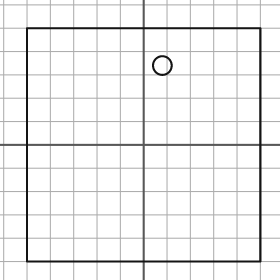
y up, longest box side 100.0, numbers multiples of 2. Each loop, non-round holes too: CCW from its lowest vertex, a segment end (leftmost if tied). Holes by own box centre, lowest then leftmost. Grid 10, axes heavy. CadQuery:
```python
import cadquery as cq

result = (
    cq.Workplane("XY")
    .moveTo(-50.0, -50.0)
    .lineTo(50.0, -50.0)
    .lineTo(50.0, 50.0)
    .lineTo(-50.0, 50.0)
    .close()
    .moveTo(8.0, 34.0)
    .circle(4.0)
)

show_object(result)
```